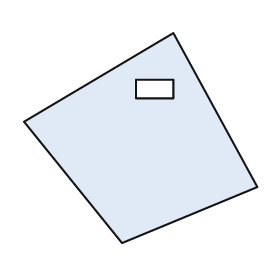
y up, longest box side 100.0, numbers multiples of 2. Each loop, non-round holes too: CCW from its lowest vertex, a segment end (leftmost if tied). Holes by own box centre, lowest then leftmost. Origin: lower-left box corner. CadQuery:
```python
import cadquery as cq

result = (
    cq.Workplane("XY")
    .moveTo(42.0, 0.0)
    .lineTo(100.0, 24.0)
    .lineTo(64.0, 90.0)
    .lineTo(0.0, 52.0)
    .close()
    .moveTo(48.0, 62.0)
    .lineTo(64.0, 62.0)
    .lineTo(64.0, 70.0)
    .lineTo(48.0, 70.0)
    .close()
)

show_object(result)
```